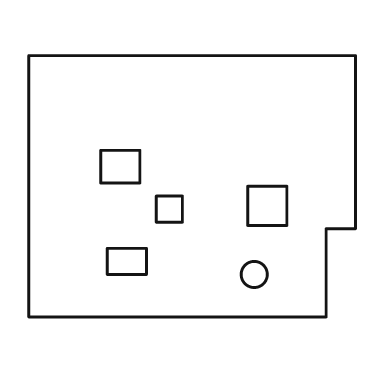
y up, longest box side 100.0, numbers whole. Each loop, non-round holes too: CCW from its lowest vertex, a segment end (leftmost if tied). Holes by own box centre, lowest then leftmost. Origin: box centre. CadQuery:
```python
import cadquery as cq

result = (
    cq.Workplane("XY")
    .moveTo(-50.0, -40.0)
    .lineTo(41.0, -40.0)
    .lineTo(41.0, -13.0)
    .lineTo(50.0, -13.0)
    .lineTo(50.0, 40.0)
    .lineTo(-50.0, 40.0)
    .close()
    .moveTo(19.0, -27.0)
    .circle(4.0)
    .moveTo(-26.0, -27.0)
    .lineTo(-14.0, -27.0)
    .lineTo(-14.0, -19.0)
    .lineTo(-26.0, -19.0)
    .close()
    .moveTo(-11.0, -11.0)
    .lineTo(-3.0, -11.0)
    .lineTo(-3.0, -3.0)
    .lineTo(-11.0, -3.0)
    .close()
    .moveTo(17.0, -12.0)
    .lineTo(29.0, -12.0)
    .lineTo(29.0, 0.0)
    .lineTo(17.0, 0.0)
    .close()
    .moveTo(-28.0, 1.0)
    .lineTo(-16.0, 1.0)
    .lineTo(-16.0, 11.0)
    .lineTo(-28.0, 11.0)
    .close()
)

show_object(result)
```